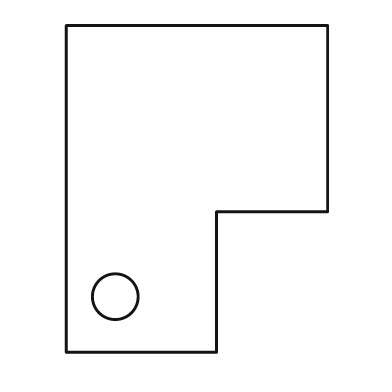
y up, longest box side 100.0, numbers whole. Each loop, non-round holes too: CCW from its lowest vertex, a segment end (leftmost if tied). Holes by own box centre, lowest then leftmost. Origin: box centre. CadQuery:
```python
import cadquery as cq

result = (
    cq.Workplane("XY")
    .moveTo(-40.0, -50.0)
    .lineTo(6.0, -50.0)
    .lineTo(6.0, -7.0)
    .lineTo(40.0, -7.0)
    .lineTo(40.0, 50.0)
    .lineTo(-40.0, 50.0)
    .close()
    .moveTo(-25.0, -33.0)
    .circle(7.0)
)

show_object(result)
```